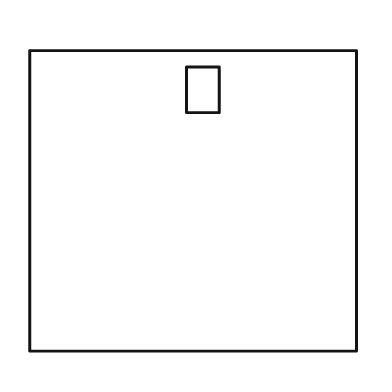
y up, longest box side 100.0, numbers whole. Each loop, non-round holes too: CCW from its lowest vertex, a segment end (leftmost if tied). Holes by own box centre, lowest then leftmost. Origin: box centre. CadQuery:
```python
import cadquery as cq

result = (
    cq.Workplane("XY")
    .moveTo(-50.0, -46.0)
    .lineTo(50.0, -46.0)
    .lineTo(50.0, 46.0)
    .lineTo(-50.0, 46.0)
    .close()
    .moveTo(-2.0, 27.0)
    .lineTo(8.0, 27.0)
    .lineTo(8.0, 41.0)
    .lineTo(-2.0, 41.0)
    .close()
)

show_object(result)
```